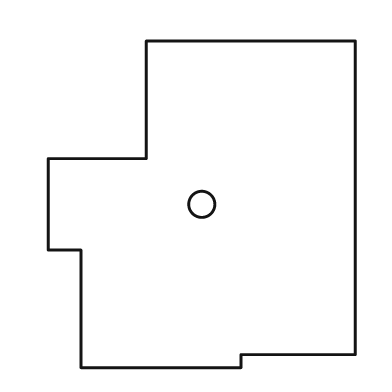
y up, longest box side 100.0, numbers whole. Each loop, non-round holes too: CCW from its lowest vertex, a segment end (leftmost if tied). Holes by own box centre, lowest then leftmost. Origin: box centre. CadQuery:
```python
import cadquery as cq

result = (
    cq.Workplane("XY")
    .moveTo(-37.0, -50.0)
    .lineTo(12.0, -50.0)
    .lineTo(12.0, -46.0)
    .lineTo(47.0, -46.0)
    .lineTo(47.0, 50.0)
    .lineTo(-17.0, 50.0)
    .lineTo(-17.0, 14.0)
    .lineTo(-47.0, 14.0)
    .lineTo(-47.0, -14.0)
    .lineTo(-37.0, -14.0)
    .close()
    .moveTo(0.0, 0.0)
    .circle(4.0)
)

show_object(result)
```